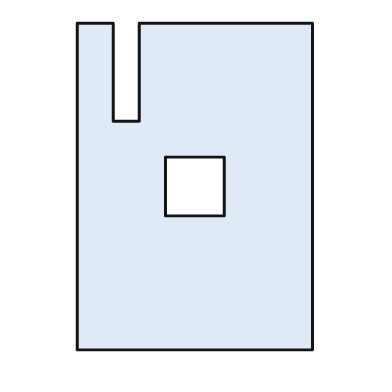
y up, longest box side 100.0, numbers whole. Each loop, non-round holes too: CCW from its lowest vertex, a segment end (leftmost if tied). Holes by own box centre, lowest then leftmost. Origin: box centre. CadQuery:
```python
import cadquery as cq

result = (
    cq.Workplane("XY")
    .moveTo(-36.0, -50.0)
    .lineTo(36.0, -50.0)
    .lineTo(36.0, 50.0)
    .lineTo(-17.0, 50.0)
    .lineTo(-17.0, 20.0)
    .lineTo(-25.0, 20.0)
    .lineTo(-25.0, 50.0)
    .lineTo(-36.0, 50.0)
    .close()
    .moveTo(-9.0, -9.0)
    .lineTo(9.0, -9.0)
    .lineTo(9.0, 9.0)
    .lineTo(-9.0, 9.0)
    .close()
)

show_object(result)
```